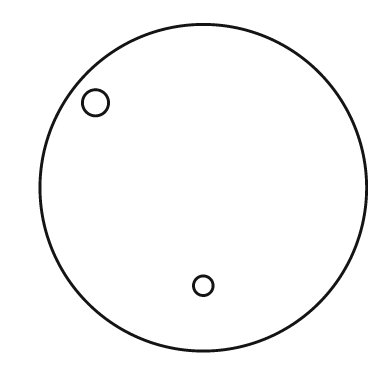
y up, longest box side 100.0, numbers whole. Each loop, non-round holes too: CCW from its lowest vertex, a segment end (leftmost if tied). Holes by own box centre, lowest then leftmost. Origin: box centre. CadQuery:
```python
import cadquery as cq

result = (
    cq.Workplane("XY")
    .moveTo(0.0, 0.0)
    .circle(50.0)
    .moveTo(0.0, -30.0)
    .circle(3.0)
    .moveTo(-33.0, 26.0)
    .circle(4.0)
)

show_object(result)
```